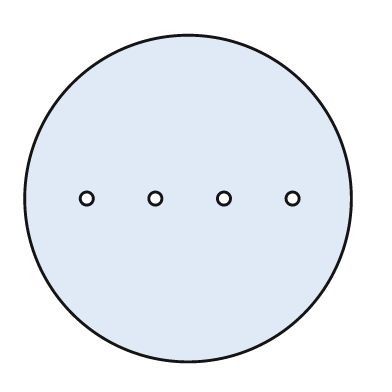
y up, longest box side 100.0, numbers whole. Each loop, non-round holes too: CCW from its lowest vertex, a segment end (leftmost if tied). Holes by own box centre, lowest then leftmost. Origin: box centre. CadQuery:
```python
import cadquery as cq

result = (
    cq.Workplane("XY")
    .moveTo(0.0, 0.0)
    .circle(50.0)
    .moveTo(-31.0, 0.0)
    .circle(2.0)
    .moveTo(-10.0, 0.0)
    .circle(2.0)
    .moveTo(11.0, 0.0)
    .circle(2.0)
    .moveTo(32.0, 0.0)
    .circle(2.0)
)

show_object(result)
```